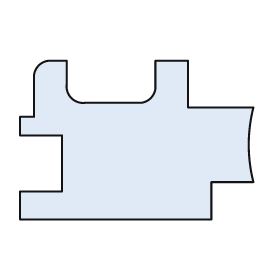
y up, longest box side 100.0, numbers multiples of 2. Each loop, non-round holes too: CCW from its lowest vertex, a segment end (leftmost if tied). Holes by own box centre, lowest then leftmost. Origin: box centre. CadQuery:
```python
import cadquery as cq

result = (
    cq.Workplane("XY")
    .moveTo(-50.0, -34.0)
    .lineTo(32.0, -34.0)
    .lineTo(32.0, -18.0)
    .lineTo(50.0, -18.0)
    .threePointArc((48.0, -2.0), (50.0, 14.0))
    .lineTo(22.0, 14.0)
    .lineTo(22.0, 34.0)
    .lineTo(8.0, 34.0)
    .lineTo(8.0, 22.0)
    .threePointArc((6.0, 18.0), (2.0, 16.0))
    .lineTo(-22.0, 16.0)
    .threePointArc((-28.0, 18.0), (-30.0, 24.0))
    .lineTo(-30.0, 34.0)
    .lineTo(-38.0, 34.0)
    .threePointArc((-42.0, 32.0), (-44.0, 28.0))
    .lineTo(-44.0, 10.0)
    .lineTo(-50.0, 10.0)
    .lineTo(-50.0, 2.0)
    .lineTo(-32.0, 2.0)
    .lineTo(-32.0, -22.0)
    .lineTo(-50.0, -22.0)
    .close()
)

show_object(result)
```